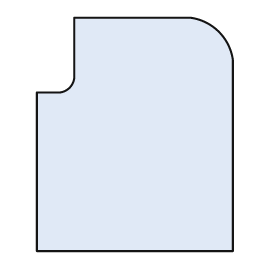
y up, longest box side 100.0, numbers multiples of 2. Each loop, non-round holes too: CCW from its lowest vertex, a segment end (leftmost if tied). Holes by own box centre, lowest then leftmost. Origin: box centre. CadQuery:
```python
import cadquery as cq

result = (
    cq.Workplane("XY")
    .moveTo(-42.0, -50.0)
    .lineTo(42.0, -50.0)
    .lineTo(42.0, 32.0)
    .threePointArc((36.0, 44.0), (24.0, 50.0))
    .lineTo(-26.0, 50.0)
    .lineTo(-26.0, 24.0)
    .threePointArc((-28.0, 20.0), (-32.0, 18.0))
    .lineTo(-42.0, 18.0)
    .close()
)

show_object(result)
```